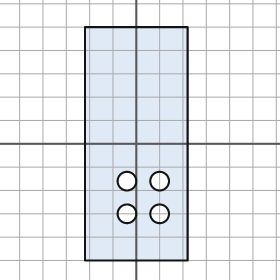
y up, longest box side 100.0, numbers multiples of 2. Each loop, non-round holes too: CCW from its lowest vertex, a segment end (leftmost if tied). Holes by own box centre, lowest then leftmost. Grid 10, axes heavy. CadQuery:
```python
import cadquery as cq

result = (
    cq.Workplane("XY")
    .moveTo(-22.0, -50.0)
    .lineTo(22.0, -50.0)
    .lineTo(22.0, 50.0)
    .lineTo(-22.0, 50.0)
    .close()
    .moveTo(-4.0, -30.0)
    .circle(4.0)
    .moveTo(10.0, -30.0)
    .circle(4.0)
    .moveTo(-4.0, -16.0)
    .circle(4.0)
    .moveTo(10.0, -16.0)
    .circle(4.0)
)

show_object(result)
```